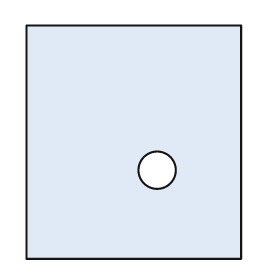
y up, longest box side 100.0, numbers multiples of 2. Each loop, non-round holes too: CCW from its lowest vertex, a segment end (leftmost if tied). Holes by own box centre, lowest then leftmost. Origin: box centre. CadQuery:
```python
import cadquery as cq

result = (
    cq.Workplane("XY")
    .moveTo(-46.0, -50.0)
    .lineTo(46.0, -50.0)
    .lineTo(46.0, 50.0)
    .lineTo(-46.0, 50.0)
    .close()
    .moveTo(10.0, -12.0)
    .circle(8.0)
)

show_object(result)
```